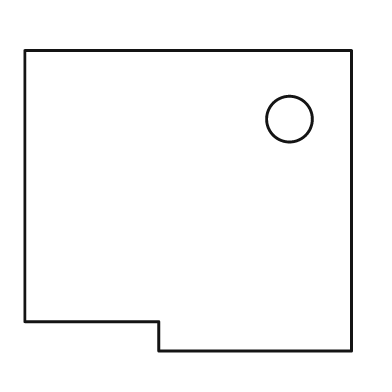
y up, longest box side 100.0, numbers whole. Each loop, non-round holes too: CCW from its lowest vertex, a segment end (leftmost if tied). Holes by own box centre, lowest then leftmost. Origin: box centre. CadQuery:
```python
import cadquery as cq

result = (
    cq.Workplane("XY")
    .moveTo(-9.0, -46.0)
    .lineTo(50.0, -46.0)
    .lineTo(50.0, 46.0)
    .lineTo(-50.0, 46.0)
    .lineTo(-50.0, -37.0)
    .lineTo(-9.0, -37.0)
    .close()
    .moveTo(31.0, 25.0)
    .circle(7.0)
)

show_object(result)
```